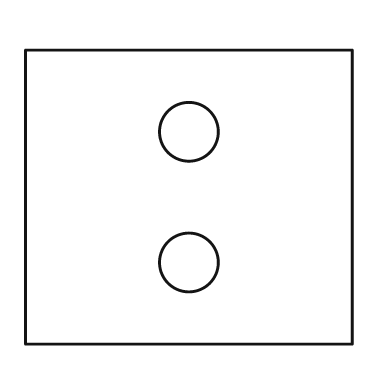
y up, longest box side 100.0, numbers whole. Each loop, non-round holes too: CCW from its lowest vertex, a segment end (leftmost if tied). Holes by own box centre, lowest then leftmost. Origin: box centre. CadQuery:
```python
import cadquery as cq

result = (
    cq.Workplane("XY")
    .moveTo(-50.0, -45.0)
    .lineTo(50.0, -45.0)
    .lineTo(50.0, 45.0)
    .lineTo(-50.0, 45.0)
    .close()
    .moveTo(0.0, -20.0)
    .circle(9.0)
    .moveTo(0.0, 20.0)
    .circle(9.0)
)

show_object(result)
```